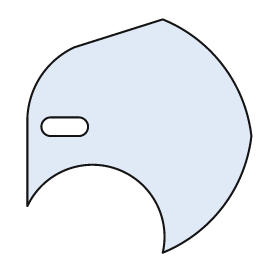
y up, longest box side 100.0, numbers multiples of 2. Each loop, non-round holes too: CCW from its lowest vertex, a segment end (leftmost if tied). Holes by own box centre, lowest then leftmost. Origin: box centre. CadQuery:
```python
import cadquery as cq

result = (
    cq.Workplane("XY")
    .moveTo(10.0, -50.0)
    .threePointArc((36.0, -30.0), (48.0, 0.0))
    .threePointArc((36.0, 30.0), (10.0, 50.0))
    .lineTo(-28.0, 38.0)
    .threePointArc((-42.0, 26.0), (-48.0, 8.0))
    .lineTo(-48.0, -30.0)
    .threePointArc((-10.0, -14.0), (10.0, -50.0))
    .close()
    .moveTo(-38.0, 0.0)
    .lineTo(-26.0, 0.0)
    .threePointArc((-22.0, 4.0), (-26.0, 8.0))
    .lineTo(-38.0, 8.0)
    .threePointArc((-42.0, 4.0), (-38.0, 0.0))
    .close()
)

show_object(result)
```